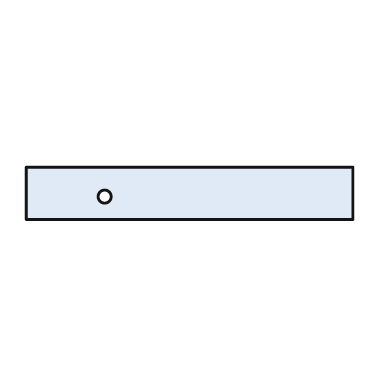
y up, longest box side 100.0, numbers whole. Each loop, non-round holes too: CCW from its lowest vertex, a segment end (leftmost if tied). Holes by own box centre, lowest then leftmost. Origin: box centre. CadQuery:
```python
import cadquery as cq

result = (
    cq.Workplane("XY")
    .moveTo(-50.0, -8.0)
    .lineTo(50.0, -8.0)
    .lineTo(50.0, 8.0)
    .lineTo(-50.0, 8.0)
    .close()
    .moveTo(-26.0, -1.0)
    .circle(2.0)
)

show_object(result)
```